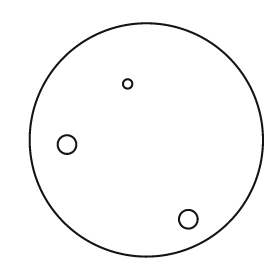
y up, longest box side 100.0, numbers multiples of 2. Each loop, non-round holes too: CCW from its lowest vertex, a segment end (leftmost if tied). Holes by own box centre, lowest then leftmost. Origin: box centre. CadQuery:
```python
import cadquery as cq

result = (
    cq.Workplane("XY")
    .moveTo(0.0, 0.0)
    .circle(50.0)
    .moveTo(18.0, -34.0)
    .circle(4.0)
    .moveTo(-34.0, -2.0)
    .circle(4.0)
    .moveTo(-8.0, 24.0)
    .circle(2.0)
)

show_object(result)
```